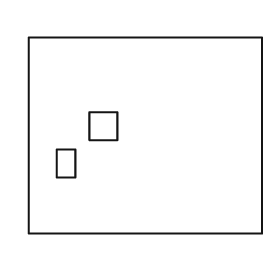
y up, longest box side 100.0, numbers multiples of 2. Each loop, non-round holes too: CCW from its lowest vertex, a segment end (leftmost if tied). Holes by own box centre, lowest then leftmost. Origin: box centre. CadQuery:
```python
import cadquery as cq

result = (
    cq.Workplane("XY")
    .moveTo(-50.0, -42.0)
    .lineTo(50.0, -42.0)
    .lineTo(50.0, 42.0)
    .lineTo(-50.0, 42.0)
    .close()
    .moveTo(-38.0, -18.0)
    .lineTo(-30.0, -18.0)
    .lineTo(-30.0, -6.0)
    .lineTo(-38.0, -6.0)
    .close()
    .moveTo(-24.0, -2.0)
    .lineTo(-12.0, -2.0)
    .lineTo(-12.0, 10.0)
    .lineTo(-24.0, 10.0)
    .close()
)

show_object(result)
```